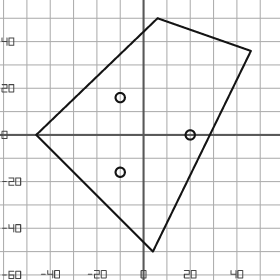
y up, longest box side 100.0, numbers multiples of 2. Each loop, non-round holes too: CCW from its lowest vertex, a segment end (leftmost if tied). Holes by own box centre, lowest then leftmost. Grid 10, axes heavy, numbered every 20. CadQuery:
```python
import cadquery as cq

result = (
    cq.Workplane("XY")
    .moveTo(4.0, -50.0)
    .lineTo(46.0, 36.0)
    .lineTo(6.0, 50.0)
    .lineTo(-46.0, 0.0)
    .close()
    .moveTo(-10.0, -16.0)
    .circle(2.0)
    .moveTo(20.0, 0.0)
    .circle(2.0)
    .moveTo(-10.0, 16.0)
    .circle(2.0)
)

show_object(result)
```